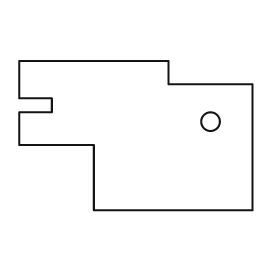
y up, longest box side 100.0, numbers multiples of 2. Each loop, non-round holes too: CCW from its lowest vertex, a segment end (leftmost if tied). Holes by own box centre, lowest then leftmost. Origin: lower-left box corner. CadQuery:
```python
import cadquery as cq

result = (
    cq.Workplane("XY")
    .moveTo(32.0, 0.0)
    .lineTo(100.0, 0.0)
    .lineTo(100.0, 54.0)
    .lineTo(64.0, 54.0)
    .lineTo(64.0, 64.0)
    .lineTo(0.0, 64.0)
    .lineTo(0.0, 48.0)
    .lineTo(14.0, 48.0)
    .lineTo(14.0, 42.0)
    .lineTo(0.0, 42.0)
    .lineTo(0.0, 28.0)
    .lineTo(32.0, 28.0)
    .close()
    .moveTo(82.0, 38.0)
    .circle(4.0)
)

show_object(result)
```